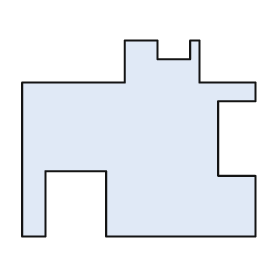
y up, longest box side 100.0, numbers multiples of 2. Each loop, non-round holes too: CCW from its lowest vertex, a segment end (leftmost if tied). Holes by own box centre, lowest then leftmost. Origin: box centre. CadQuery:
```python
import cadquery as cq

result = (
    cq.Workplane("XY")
    .moveTo(-50.0, -42.0)
    .lineTo(-40.0, -42.0)
    .lineTo(-40.0, -14.0)
    .lineTo(-14.0, -14.0)
    .lineTo(-14.0, -42.0)
    .lineTo(50.0, -42.0)
    .lineTo(50.0, -16.0)
    .lineTo(34.0, -16.0)
    .lineTo(34.0, 16.0)
    .lineTo(50.0, 16.0)
    .lineTo(50.0, 24.0)
    .lineTo(26.0, 24.0)
    .lineTo(26.0, 42.0)
    .lineTo(22.0, 42.0)
    .lineTo(22.0, 34.0)
    .lineTo(8.0, 34.0)
    .lineTo(8.0, 42.0)
    .lineTo(-6.0, 42.0)
    .lineTo(-6.0, 24.0)
    .lineTo(-50.0, 24.0)
    .close()
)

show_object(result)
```